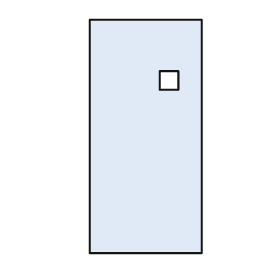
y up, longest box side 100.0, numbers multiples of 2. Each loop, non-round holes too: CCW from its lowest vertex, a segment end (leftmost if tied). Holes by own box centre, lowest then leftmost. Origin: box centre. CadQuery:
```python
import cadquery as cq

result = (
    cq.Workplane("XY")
    .moveTo(-24.0, -50.0)
    .lineTo(24.0, -50.0)
    .lineTo(24.0, 50.0)
    .lineTo(-24.0, 50.0)
    .close()
    .moveTo(6.0, 20.0)
    .lineTo(14.0, 20.0)
    .lineTo(14.0, 28.0)
    .lineTo(6.0, 28.0)
    .close()
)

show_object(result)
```